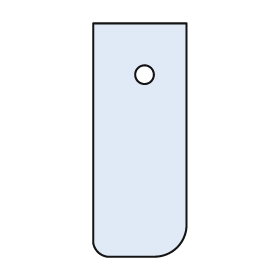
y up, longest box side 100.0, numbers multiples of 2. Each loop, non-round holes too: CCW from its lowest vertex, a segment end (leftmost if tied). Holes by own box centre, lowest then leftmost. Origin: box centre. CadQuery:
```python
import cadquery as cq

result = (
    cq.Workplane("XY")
    .moveTo(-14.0, -50.0)
    .lineTo(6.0, -50.0)
    .threePointArc((16.0, -46.0), (20.0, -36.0))
    .lineTo(20.0, 50.0)
    .lineTo(-20.0, 50.0)
    .lineTo(-20.0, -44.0)
    .threePointArc((-18.0, -48.0), (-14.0, -50.0))
    .close()
    .moveTo(2.0, 28.0)
    .circle(4.0)
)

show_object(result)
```